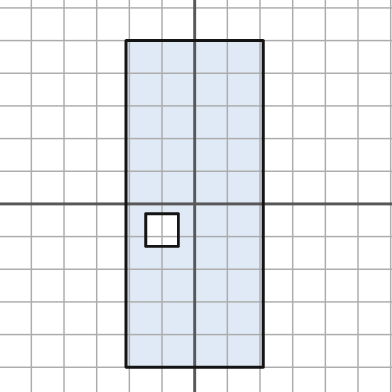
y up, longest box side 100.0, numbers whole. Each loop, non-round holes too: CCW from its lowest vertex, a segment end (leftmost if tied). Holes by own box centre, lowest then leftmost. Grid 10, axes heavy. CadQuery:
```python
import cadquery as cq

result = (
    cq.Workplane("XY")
    .moveTo(-21.0, -50.0)
    .lineTo(21.0, -50.0)
    .lineTo(21.0, 50.0)
    .lineTo(-21.0, 50.0)
    .close()
    .moveTo(-15.0, -13.0)
    .lineTo(-5.0, -13.0)
    .lineTo(-5.0, -3.0)
    .lineTo(-15.0, -3.0)
    .close()
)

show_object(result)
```